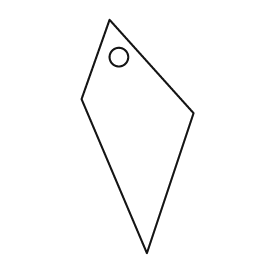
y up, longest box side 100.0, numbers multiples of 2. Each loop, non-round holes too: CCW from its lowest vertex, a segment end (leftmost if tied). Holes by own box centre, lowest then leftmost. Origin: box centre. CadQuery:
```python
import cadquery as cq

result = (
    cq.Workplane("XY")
    .moveTo(4.0, -50.0)
    .lineTo(24.0, 10.0)
    .lineTo(-12.0, 50.0)
    .lineTo(-24.0, 16.0)
    .close()
    .moveTo(-8.0, 34.0)
    .circle(4.0)
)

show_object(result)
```